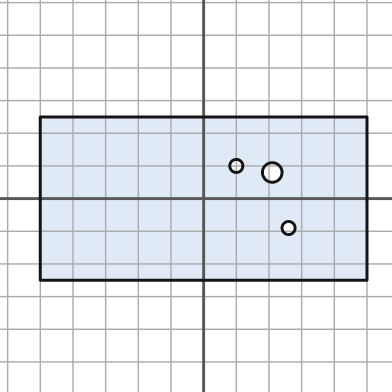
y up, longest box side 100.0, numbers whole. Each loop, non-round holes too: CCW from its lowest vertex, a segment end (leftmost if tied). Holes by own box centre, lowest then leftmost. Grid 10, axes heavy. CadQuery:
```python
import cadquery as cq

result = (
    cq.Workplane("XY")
    .moveTo(-50.0, -25.0)
    .lineTo(50.0, -25.0)
    .lineTo(50.0, 25.0)
    .lineTo(-50.0, 25.0)
    .close()
    .moveTo(26.0, -9.0)
    .circle(2.0)
    .moveTo(21.0, 8.0)
    .circle(3.0)
    .moveTo(10.0, 10.0)
    .circle(2.0)
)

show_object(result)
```